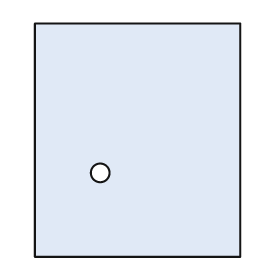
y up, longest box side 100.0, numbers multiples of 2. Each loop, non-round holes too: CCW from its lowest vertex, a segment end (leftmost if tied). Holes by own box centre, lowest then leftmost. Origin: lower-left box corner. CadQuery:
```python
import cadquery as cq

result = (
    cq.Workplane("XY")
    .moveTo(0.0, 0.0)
    .lineTo(88.0, 0.0)
    .lineTo(88.0, 100.0)
    .lineTo(0.0, 100.0)
    .close()
    .moveTo(28.0, 36.0)
    .circle(4.0)
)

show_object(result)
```